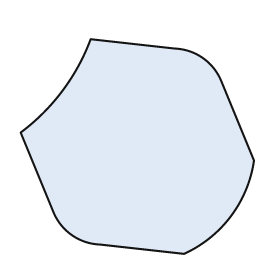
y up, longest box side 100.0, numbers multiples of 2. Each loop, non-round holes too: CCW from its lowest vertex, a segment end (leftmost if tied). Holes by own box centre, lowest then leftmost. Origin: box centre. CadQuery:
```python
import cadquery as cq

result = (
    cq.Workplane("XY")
    .moveTo(20.0, -46.0)
    .threePointArc((40.0, -30.0), (50.0, -6.0))
    .lineTo(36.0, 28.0)
    .threePointArc((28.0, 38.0), (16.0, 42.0))
    .lineTo(-20.0, 46.0)
    .threePointArc((-32.0, 24.0), (-50.0, 6.0))
    .lineTo(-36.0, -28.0)
    .threePointArc((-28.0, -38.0), (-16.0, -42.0))
    .close()
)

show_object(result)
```